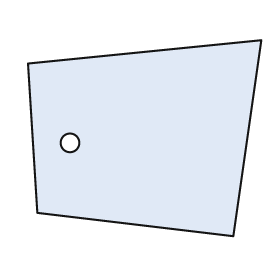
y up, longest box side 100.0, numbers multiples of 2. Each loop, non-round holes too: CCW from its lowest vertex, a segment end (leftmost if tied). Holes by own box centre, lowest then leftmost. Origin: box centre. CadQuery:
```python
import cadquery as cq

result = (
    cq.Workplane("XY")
    .moveTo(38.0, -42.0)
    .lineTo(50.0, 42.0)
    .lineTo(-50.0, 32.0)
    .lineTo(-46.0, -32.0)
    .close()
    .moveTo(-32.0, -2.0)
    .circle(4.0)
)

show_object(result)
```